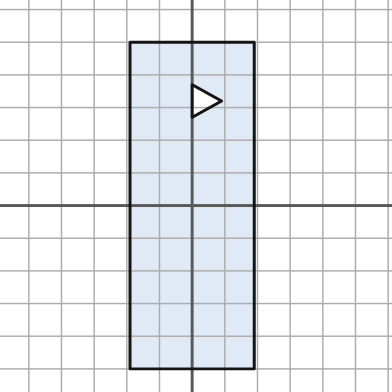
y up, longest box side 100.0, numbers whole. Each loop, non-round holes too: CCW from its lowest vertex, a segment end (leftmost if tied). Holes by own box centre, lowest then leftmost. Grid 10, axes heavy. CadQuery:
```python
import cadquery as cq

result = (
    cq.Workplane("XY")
    .moveTo(-19.0, -50.0)
    .lineTo(19.0, -50.0)
    .lineTo(19.0, 50.0)
    .lineTo(-19.0, 50.0)
    .close()
    .moveTo(0.0, 27.0)
    .lineTo(9.0, 32.0)
    .lineTo(0.0, 37.0)
    .close()
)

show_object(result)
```